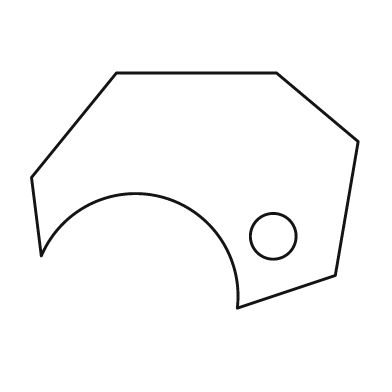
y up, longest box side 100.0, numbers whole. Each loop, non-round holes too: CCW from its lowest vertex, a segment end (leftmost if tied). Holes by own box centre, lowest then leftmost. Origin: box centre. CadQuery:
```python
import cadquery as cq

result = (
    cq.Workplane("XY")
    .moveTo(13.0, -36.0)
    .lineTo(43.0, -26.0)
    .lineTo(50.0, 15.0)
    .lineTo(25.0, 36.0)
    .lineTo(-24.0, 36.0)
    .lineTo(-50.0, 4.0)
    .lineTo(-47.0, -20.0)
    .threePointArc((-10.0, -2.0), (13.0, -36.0))
    .close()
    .moveTo(24.0, -14.0)
    .circle(7.0)
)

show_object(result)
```